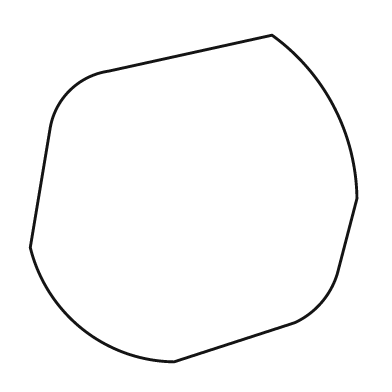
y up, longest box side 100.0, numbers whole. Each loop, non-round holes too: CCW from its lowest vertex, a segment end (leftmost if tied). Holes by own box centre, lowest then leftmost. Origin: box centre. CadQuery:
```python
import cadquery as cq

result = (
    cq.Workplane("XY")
    .moveTo(-6.0, -50.0)
    .lineTo(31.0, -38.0)
    .threePointArc((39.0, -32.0), (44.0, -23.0))
    .lineTo(50.0, 0.0)
    .threePointArc((43.0, 28.0), (24.0, 50.0))
    .lineTo(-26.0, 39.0)
    .threePointArc((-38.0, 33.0), (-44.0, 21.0))
    .lineTo(-50.0, -15.0)
    .threePointArc((-34.0, -40.0), (-6.0, -50.0))
    .close()
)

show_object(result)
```